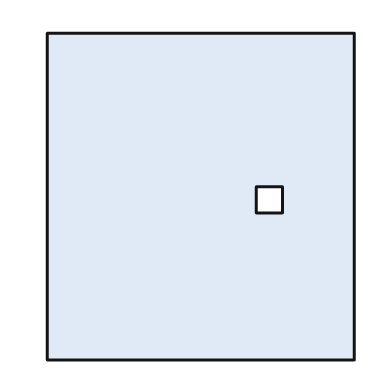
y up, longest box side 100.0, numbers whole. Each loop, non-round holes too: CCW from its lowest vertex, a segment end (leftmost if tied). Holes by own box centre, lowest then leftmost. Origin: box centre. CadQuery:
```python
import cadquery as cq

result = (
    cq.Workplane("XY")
    .moveTo(-47.0, -50.0)
    .lineTo(47.0, -50.0)
    .lineTo(47.0, 50.0)
    .lineTo(-47.0, 50.0)
    .close()
    .moveTo(17.0, -5.0)
    .lineTo(25.0, -5.0)
    .lineTo(25.0, 3.0)
    .lineTo(17.0, 3.0)
    .close()
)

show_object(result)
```